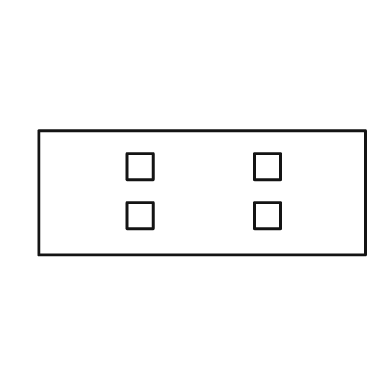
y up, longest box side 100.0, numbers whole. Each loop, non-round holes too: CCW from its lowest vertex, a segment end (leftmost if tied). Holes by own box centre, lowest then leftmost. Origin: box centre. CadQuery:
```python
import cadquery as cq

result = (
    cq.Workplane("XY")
    .moveTo(-50.0, -19.0)
    .lineTo(50.0, -19.0)
    .lineTo(50.0, 19.0)
    .lineTo(-50.0, 19.0)
    .close()
    .moveTo(-23.0, -11.0)
    .lineTo(-15.0, -11.0)
    .lineTo(-15.0, -3.0)
    .lineTo(-23.0, -3.0)
    .close()
    .moveTo(16.0, -11.0)
    .lineTo(24.0, -11.0)
    .lineTo(24.0, -3.0)
    .lineTo(16.0, -3.0)
    .close()
    .moveTo(-23.0, 4.0)
    .lineTo(-15.0, 4.0)
    .lineTo(-15.0, 12.0)
    .lineTo(-23.0, 12.0)
    .close()
    .moveTo(16.0, 4.0)
    .lineTo(24.0, 4.0)
    .lineTo(24.0, 12.0)
    .lineTo(16.0, 12.0)
    .close()
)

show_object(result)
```